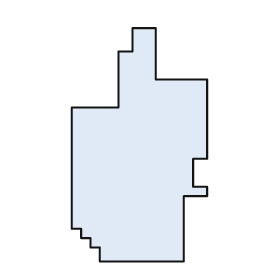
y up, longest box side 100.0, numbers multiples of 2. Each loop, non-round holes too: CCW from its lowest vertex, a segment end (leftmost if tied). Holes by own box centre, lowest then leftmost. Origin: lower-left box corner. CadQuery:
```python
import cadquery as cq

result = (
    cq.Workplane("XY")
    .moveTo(12.0, 0.0)
    .lineTo(48.0, 0.0)
    .lineTo(48.0, 28.0)
    .lineTo(58.0, 28.0)
    .lineTo(58.0, 32.0)
    .lineTo(52.0, 32.0)
    .lineTo(52.0, 44.0)
    .lineTo(58.0, 44.0)
    .lineTo(58.0, 78.0)
    .lineTo(36.0, 78.0)
    .lineTo(36.0, 100.0)
    .lineTo(26.0, 100.0)
    .lineTo(26.0, 90.0)
    .lineTo(20.0, 90.0)
    .lineTo(20.0, 66.0)
    .lineTo(0.0, 66.0)
    .lineTo(0.0, 14.0)
    .lineTo(4.0, 14.0)
    .lineTo(4.0, 10.0)
    .lineTo(8.0, 10.0)
    .lineTo(8.0, 6.0)
    .lineTo(12.0, 6.0)
    .close()
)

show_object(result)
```